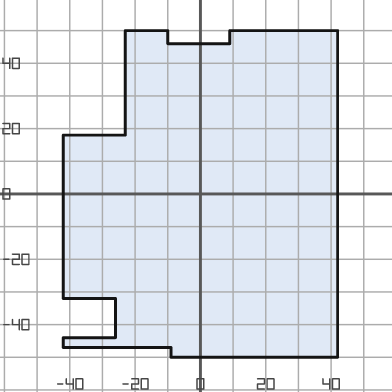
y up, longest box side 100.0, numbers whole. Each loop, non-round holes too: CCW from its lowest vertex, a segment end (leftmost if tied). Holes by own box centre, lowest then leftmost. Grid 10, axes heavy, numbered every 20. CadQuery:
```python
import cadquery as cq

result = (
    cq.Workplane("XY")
    .moveTo(-9.0, -50.0)
    .lineTo(42.0, -50.0)
    .lineTo(42.0, 50.0)
    .lineTo(9.0, 50.0)
    .lineTo(9.0, 46.0)
    .lineTo(-10.0, 46.0)
    .lineTo(-10.0, 50.0)
    .lineTo(-23.0, 50.0)
    .lineTo(-23.0, 18.0)
    .lineTo(-42.0, 18.0)
    .lineTo(-42.0, -32.0)
    .lineTo(-26.0, -32.0)
    .lineTo(-26.0, -44.0)
    .lineTo(-42.0, -44.0)
    .lineTo(-42.0, -47.0)
    .lineTo(-9.0, -47.0)
    .close()
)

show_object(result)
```